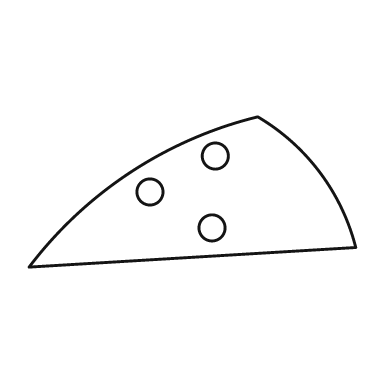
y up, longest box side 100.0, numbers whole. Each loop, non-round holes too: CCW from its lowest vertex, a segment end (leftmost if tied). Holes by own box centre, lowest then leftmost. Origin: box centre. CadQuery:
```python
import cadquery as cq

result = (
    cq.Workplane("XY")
    .moveTo(-50.0, -23.0)
    .lineTo(50.0, -17.0)
    .threePointArc((39.0, 6.0), (20.0, 23.0))
    .threePointArc((-19.0, 6.0), (-50.0, -23.0))
    .close()
    .moveTo(6.0, -11.0)
    .circle(4.0)
    .moveTo(-13.0, 0.0)
    .circle(4.0)
    .moveTo(7.0, 11.0)
    .circle(4.0)
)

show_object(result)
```